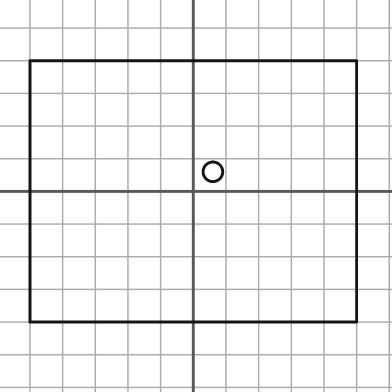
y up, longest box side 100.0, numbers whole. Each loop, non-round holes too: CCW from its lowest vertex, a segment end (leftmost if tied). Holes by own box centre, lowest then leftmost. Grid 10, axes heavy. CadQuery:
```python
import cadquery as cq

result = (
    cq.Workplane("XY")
    .moveTo(-50.0, -40.0)
    .lineTo(50.0, -40.0)
    .lineTo(50.0, 40.0)
    .lineTo(-50.0, 40.0)
    .close()
    .moveTo(6.0, 6.0)
    .circle(3.0)
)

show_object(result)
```